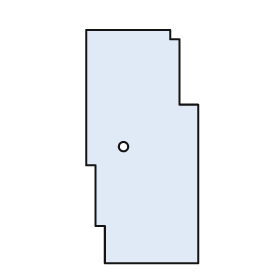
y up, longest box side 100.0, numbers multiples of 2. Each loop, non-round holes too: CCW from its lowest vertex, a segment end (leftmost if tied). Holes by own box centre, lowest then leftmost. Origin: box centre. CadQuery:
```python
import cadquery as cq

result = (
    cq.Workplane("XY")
    .moveTo(-16.0, -50.0)
    .lineTo(24.0, -50.0)
    .lineTo(24.0, 18.0)
    .lineTo(16.0, 18.0)
    .lineTo(16.0, 46.0)
    .lineTo(12.0, 46.0)
    .lineTo(12.0, 50.0)
    .lineTo(-24.0, 50.0)
    .lineTo(-24.0, -8.0)
    .lineTo(-20.0, -8.0)
    .lineTo(-20.0, -34.0)
    .lineTo(-16.0, -34.0)
    .close()
    .moveTo(-8.0, 0.0)
    .circle(2.0)
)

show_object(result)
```